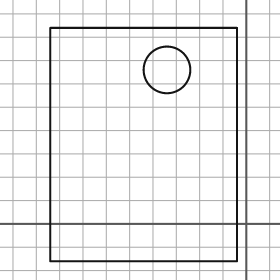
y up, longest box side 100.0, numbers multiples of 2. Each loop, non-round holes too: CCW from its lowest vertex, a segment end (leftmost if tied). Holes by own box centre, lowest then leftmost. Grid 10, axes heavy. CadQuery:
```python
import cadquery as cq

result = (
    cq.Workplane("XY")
    .moveTo(-84.0, -16.0)
    .lineTo(-4.0, -16.0)
    .lineTo(-4.0, 84.0)
    .lineTo(-84.0, 84.0)
    .close()
    .moveTo(-34.0, 66.0)
    .circle(10.0)
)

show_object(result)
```